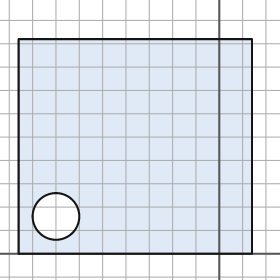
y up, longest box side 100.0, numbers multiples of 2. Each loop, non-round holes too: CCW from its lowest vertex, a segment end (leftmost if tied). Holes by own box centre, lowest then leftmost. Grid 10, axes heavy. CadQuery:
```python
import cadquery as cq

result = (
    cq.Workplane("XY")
    .moveTo(-86.0, 0.0)
    .lineTo(14.0, 0.0)
    .lineTo(14.0, 92.0)
    .lineTo(-86.0, 92.0)
    .close()
    .moveTo(-70.0, 16.0)
    .circle(10.0)
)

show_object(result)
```